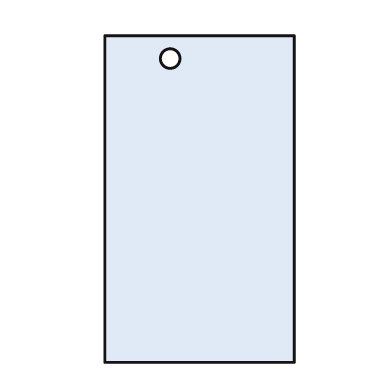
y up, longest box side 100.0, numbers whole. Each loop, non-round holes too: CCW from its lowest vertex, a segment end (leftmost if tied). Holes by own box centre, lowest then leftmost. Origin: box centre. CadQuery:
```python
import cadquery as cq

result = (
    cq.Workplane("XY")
    .moveTo(-29.0, -50.0)
    .lineTo(29.0, -50.0)
    .lineTo(29.0, 50.0)
    .lineTo(-29.0, 50.0)
    .close()
    .moveTo(-9.0, 43.0)
    .circle(3.0)
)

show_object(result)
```